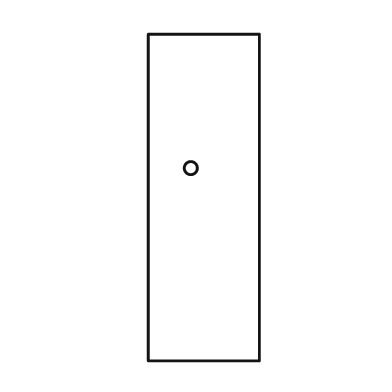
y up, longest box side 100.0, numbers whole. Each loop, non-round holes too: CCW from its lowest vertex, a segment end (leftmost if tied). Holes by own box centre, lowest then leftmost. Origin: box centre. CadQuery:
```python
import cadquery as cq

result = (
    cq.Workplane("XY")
    .moveTo(-17.0, -50.0)
    .lineTo(17.0, -50.0)
    .lineTo(17.0, 50.0)
    .lineTo(-17.0, 50.0)
    .close()
    .moveTo(-4.0, 9.0)
    .circle(2.0)
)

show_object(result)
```